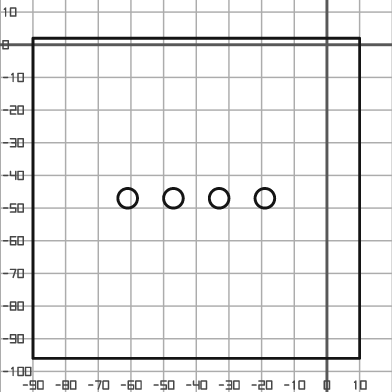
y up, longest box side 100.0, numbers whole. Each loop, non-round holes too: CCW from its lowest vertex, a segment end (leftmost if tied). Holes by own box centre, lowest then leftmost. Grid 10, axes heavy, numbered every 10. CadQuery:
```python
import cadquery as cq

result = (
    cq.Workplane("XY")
    .moveTo(-90.0, -96.0)
    .lineTo(10.0, -96.0)
    .lineTo(10.0, 2.0)
    .lineTo(-90.0, 2.0)
    .close()
    .moveTo(-61.0, -47.0)
    .circle(3.0)
    .moveTo(-47.0, -47.0)
    .circle(3.0)
    .moveTo(-33.0, -47.0)
    .circle(3.0)
    .moveTo(-19.0, -47.0)
    .circle(3.0)
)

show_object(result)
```